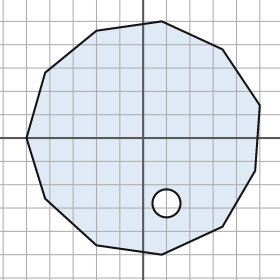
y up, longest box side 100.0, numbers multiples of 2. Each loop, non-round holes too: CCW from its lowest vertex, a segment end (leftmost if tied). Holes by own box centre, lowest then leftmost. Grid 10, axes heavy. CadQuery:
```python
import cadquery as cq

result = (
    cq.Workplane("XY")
    .moveTo(8.0, -50.0)
    .lineTo(34.0, -38.0)
    .lineTo(48.0, -14.0)
    .lineTo(50.0, 14.0)
    .lineTo(34.0, 38.0)
    .lineTo(8.0, 50.0)
    .lineTo(-20.0, 46.0)
    .lineTo(-42.0, 28.0)
    .lineTo(-50.0, 0.0)
    .lineTo(-42.0, -26.0)
    .lineTo(-20.0, -46.0)
    .close()
    .moveTo(10.0, -28.0)
    .circle(6.0)
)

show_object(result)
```